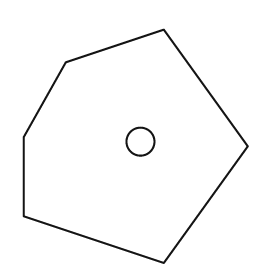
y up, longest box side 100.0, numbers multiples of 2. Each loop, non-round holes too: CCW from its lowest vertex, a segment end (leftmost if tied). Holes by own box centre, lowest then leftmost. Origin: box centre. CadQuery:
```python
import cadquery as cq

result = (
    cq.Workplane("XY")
    .moveTo(12.0, -50.0)
    .lineTo(48.0, 0.0)
    .lineTo(12.0, 50.0)
    .lineTo(-30.0, 36.0)
    .lineTo(-48.0, 4.0)
    .lineTo(-48.0, -30.0)
    .close()
    .moveTo(2.0, 2.0)
    .circle(6.0)
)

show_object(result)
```